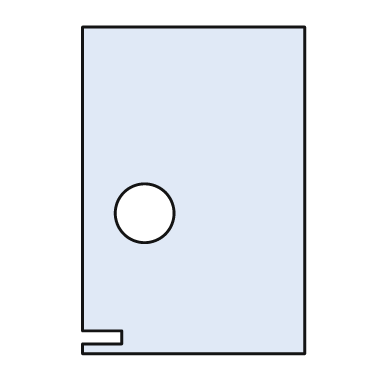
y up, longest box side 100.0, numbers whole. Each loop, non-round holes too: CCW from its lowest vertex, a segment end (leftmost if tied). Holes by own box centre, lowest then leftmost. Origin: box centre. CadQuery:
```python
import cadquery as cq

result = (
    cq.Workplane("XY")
    .moveTo(-34.0, -50.0)
    .lineTo(34.0, -50.0)
    .lineTo(34.0, 50.0)
    .lineTo(-34.0, 50.0)
    .lineTo(-34.0, -43.0)
    .lineTo(-22.0, -43.0)
    .lineTo(-22.0, -47.0)
    .lineTo(-34.0, -47.0)
    .close()
    .moveTo(-15.0, -7.0)
    .circle(9.0)
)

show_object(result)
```